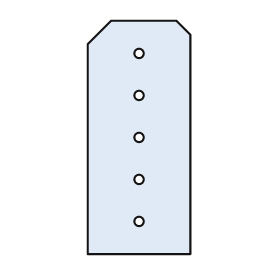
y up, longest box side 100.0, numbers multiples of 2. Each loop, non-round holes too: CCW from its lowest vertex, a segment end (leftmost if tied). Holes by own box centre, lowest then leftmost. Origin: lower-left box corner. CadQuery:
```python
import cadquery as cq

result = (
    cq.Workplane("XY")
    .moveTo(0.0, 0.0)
    .lineTo(44.0, 0.0)
    .lineTo(44.0, 94.0)
    .lineTo(38.0, 100.0)
    .lineTo(10.0, 100.0)
    .lineTo(0.0, 90.0)
    .close()
    .moveTo(22.0, 14.0)
    .circle(2.0)
    .moveTo(22.0, 32.0)
    .circle(2.0)
    .moveTo(22.0, 50.0)
    .circle(2.0)
    .moveTo(22.0, 68.0)
    .circle(2.0)
    .moveTo(22.0, 86.0)
    .circle(2.0)
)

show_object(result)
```